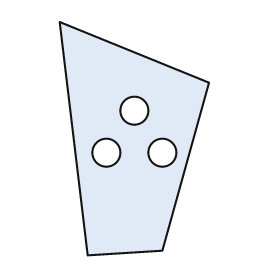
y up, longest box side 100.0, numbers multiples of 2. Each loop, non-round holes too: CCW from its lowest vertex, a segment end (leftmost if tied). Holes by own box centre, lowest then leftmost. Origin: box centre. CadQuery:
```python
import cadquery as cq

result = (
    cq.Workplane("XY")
    .moveTo(-20.0, -50.0)
    .lineTo(12.0, -48.0)
    .lineTo(32.0, 24.0)
    .lineTo(-32.0, 50.0)
    .close()
    .moveTo(-12.0, -6.0)
    .circle(6.0)
    .moveTo(12.0, -6.0)
    .circle(6.0)
    .moveTo(0.0, 12.0)
    .circle(6.0)
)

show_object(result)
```